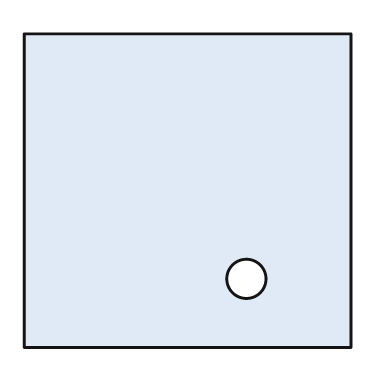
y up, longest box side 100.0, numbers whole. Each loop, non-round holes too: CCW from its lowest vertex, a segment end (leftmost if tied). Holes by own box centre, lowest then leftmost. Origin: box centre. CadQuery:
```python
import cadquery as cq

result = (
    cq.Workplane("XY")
    .moveTo(-50.0, -48.0)
    .lineTo(50.0, -48.0)
    .lineTo(50.0, 48.0)
    .lineTo(-50.0, 48.0)
    .close()
    .moveTo(18.0, -27.0)
    .circle(6.0)
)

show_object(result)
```